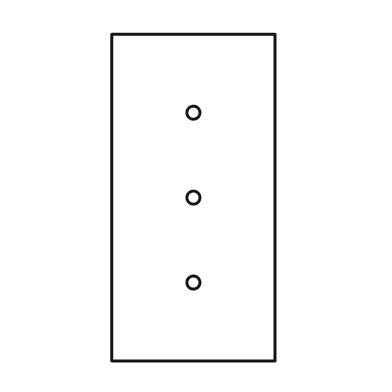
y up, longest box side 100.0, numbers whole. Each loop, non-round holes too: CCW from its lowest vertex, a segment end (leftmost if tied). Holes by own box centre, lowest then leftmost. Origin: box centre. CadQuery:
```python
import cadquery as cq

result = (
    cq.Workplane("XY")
    .moveTo(-25.0, -50.0)
    .lineTo(25.0, -50.0)
    .lineTo(25.0, 50.0)
    .lineTo(-25.0, 50.0)
    .close()
    .moveTo(0.0, -26.0)
    .circle(2.0)
    .moveTo(0.0, 0.0)
    .circle(2.0)
    .moveTo(0.0, 26.0)
    .circle(2.0)
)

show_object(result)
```